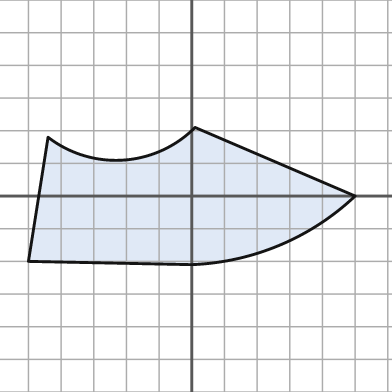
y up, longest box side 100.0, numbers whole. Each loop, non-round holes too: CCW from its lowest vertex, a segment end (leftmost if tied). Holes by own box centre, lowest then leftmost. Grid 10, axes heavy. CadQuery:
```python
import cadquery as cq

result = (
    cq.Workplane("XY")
    .moveTo(0.0, -21.0)
    .threePointArc((27.0, -15.0), (50.0, 0.0))
    .lineTo(1.0, 21.0)
    .threePointArc((-21.0, 11.0), (-44.0, 18.0))
    .lineTo(-50.0, -20.0)
    .close()
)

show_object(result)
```